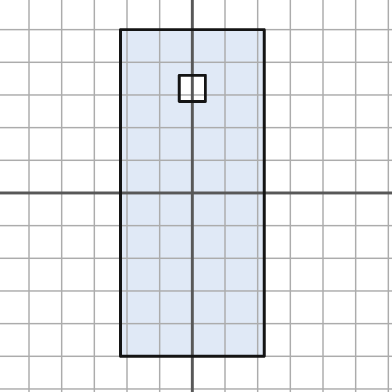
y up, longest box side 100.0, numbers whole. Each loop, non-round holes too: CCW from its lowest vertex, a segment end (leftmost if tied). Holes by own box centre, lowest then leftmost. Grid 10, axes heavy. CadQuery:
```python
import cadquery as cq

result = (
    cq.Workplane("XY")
    .moveTo(-22.0, -50.0)
    .lineTo(22.0, -50.0)
    .lineTo(22.0, 50.0)
    .lineTo(-22.0, 50.0)
    .close()
    .moveTo(-4.0, 28.0)
    .lineTo(4.0, 28.0)
    .lineTo(4.0, 36.0)
    .lineTo(-4.0, 36.0)
    .close()
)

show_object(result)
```